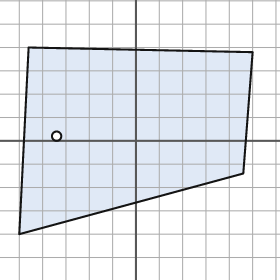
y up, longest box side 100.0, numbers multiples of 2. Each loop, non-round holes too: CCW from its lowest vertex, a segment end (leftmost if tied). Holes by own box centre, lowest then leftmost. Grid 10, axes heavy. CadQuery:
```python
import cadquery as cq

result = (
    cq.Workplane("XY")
    .moveTo(-50.0, -40.0)
    .lineTo(46.0, -14.0)
    .lineTo(50.0, 38.0)
    .lineTo(-46.0, 40.0)
    .close()
    .moveTo(-34.0, 2.0)
    .circle(2.0)
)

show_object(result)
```